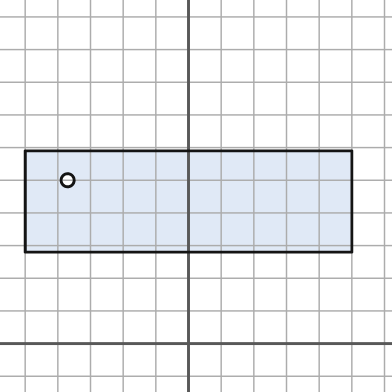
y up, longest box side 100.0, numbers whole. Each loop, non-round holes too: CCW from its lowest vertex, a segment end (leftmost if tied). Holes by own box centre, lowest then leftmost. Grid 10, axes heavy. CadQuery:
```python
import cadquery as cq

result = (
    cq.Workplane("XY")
    .moveTo(-50.0, 28.0)
    .lineTo(50.0, 28.0)
    .lineTo(50.0, 59.0)
    .lineTo(-50.0, 59.0)
    .close()
    .moveTo(-37.0, 50.0)
    .circle(2.0)
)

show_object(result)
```